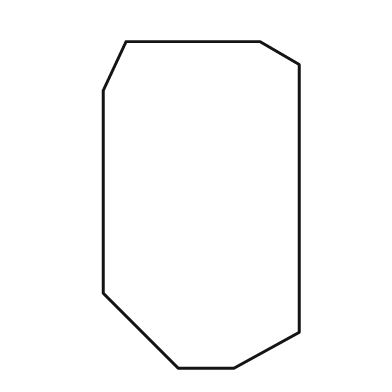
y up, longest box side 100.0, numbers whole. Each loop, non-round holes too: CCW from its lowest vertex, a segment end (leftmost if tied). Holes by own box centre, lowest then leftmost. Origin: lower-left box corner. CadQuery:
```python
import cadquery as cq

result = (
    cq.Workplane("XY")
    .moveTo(23.0, 0.0)
    .lineTo(40.0, 0.0)
    .lineTo(60.0, 11.0)
    .lineTo(60.0, 93.0)
    .lineTo(48.0, 100.0)
    .lineTo(7.0, 100.0)
    .lineTo(0.0, 85.0)
    .lineTo(0.0, 23.0)
    .close()
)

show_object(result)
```